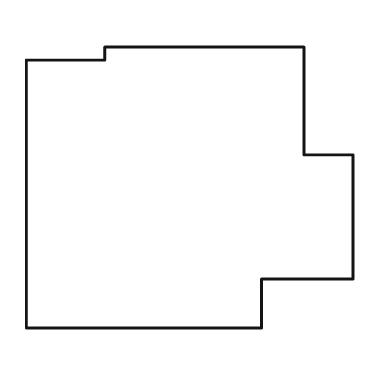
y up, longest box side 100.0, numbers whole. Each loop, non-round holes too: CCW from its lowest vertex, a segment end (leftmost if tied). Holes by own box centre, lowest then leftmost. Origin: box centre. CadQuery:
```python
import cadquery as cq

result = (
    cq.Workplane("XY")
    .moveTo(-50.0, -43.0)
    .lineTo(22.0, -43.0)
    .lineTo(22.0, -28.0)
    .lineTo(50.0, -28.0)
    .lineTo(50.0, 10.0)
    .lineTo(35.0, 10.0)
    .lineTo(35.0, 43.0)
    .lineTo(-26.0, 43.0)
    .lineTo(-26.0, 39.0)
    .lineTo(-50.0, 39.0)
    .close()
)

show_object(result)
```